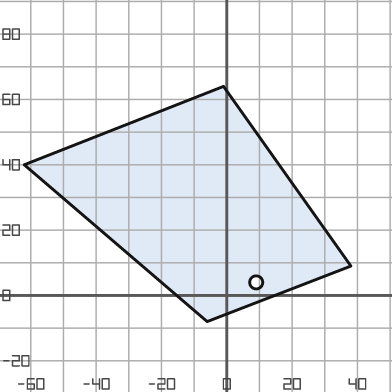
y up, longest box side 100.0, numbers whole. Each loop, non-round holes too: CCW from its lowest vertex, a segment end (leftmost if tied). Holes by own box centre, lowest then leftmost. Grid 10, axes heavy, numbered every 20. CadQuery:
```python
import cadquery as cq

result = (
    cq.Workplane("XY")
    .moveTo(-6.0, -8.0)
    .lineTo(38.0, 9.0)
    .lineTo(-1.0, 64.0)
    .lineTo(-62.0, 40.0)
    .close()
    .moveTo(9.0, 4.0)
    .circle(2.0)
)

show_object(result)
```